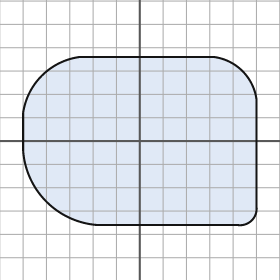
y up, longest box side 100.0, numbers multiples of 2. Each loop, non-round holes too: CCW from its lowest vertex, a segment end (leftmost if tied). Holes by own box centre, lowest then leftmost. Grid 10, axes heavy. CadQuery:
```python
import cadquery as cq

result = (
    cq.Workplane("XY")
    .moveTo(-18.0, -36.0)
    .lineTo(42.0, -36.0)
    .threePointArc((48.0, -34.0), (50.0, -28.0))
    .lineTo(50.0, 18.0)
    .threePointArc((44.0, 30.0), (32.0, 36.0))
    .lineTo(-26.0, 36.0)
    .threePointArc((-42.0, 28.0), (-50.0, 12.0))
    .lineTo(-50.0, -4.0)
    .threePointArc((-40.0, -26.0), (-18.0, -36.0))
    .close()
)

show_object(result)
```